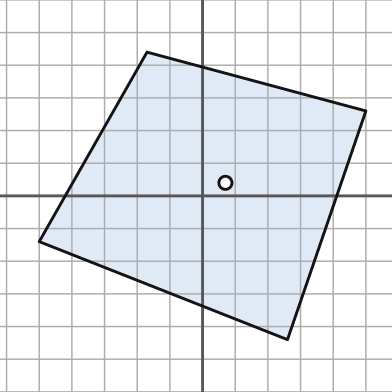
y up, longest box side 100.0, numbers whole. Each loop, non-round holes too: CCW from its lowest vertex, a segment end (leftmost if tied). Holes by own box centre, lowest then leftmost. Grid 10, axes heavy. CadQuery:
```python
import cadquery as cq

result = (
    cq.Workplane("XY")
    .moveTo(26.0, -44.0)
    .lineTo(50.0, 26.0)
    .lineTo(-17.0, 44.0)
    .lineTo(-50.0, -14.0)
    .close()
    .moveTo(7.0, 4.0)
    .circle(2.0)
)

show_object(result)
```